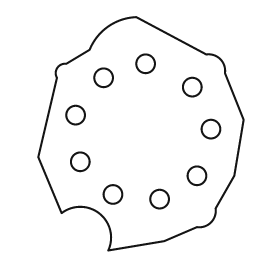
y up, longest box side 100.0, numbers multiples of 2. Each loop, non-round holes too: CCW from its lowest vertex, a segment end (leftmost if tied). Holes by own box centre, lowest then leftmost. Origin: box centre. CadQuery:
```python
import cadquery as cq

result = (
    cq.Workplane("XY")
    .moveTo(-14.0, -50.0)
    .lineTo(10.0, -46.0)
    .lineTo(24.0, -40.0)
    .threePointArc((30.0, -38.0), (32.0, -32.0))
    .lineTo(40.0, -18.0)
    .lineTo(44.0, 6.0)
    .lineTo(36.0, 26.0)
    .threePointArc((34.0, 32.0), (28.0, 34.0))
    .lineTo(-2.0, 50.0)
    .threePointArc((-14.0, 46.0), (-22.0, 36.0))
    .lineTo(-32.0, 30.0)
    .threePointArc((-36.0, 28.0), (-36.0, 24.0))
    .lineTo(-44.0, -10.0)
    .lineTo(-34.0, -34.0)
    .threePointArc((-18.0, -34.0), (-14.0, -50.0))
    .close()
    .moveTo(8.0, -28.0)
    .circle(4.0)
    .moveTo(-12.0, -26.0)
    .circle(4.0)
    .moveTo(24.0, -18.0)
    .circle(4.0)
    .moveTo(-26.0, -12.0)
    .circle(4.0)
    .moveTo(30.0, 2.0)
    .circle(4.0)
    .moveTo(-28.0, 8.0)
    .circle(4.0)
    .moveTo(22.0, 20.0)
    .circle(4.0)
    .moveTo(-16.0, 24.0)
    .circle(4.0)
    .moveTo(2.0, 30.0)
    .circle(4.0)
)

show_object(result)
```